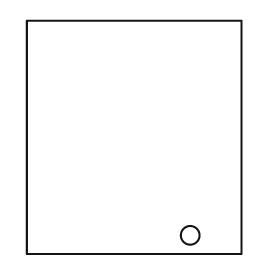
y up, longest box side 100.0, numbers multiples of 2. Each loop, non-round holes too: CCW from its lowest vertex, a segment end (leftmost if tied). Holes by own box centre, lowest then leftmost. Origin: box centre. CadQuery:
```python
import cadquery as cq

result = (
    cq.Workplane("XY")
    .moveTo(-46.0, -50.0)
    .lineTo(46.0, -50.0)
    .lineTo(46.0, 50.0)
    .lineTo(-46.0, 50.0)
    .close()
    .moveTo(24.0, -42.0)
    .circle(4.0)
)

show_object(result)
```